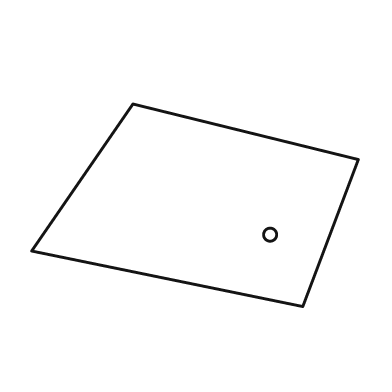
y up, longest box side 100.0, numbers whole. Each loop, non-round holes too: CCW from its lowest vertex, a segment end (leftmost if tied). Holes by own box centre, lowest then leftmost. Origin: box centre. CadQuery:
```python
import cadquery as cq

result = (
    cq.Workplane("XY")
    .moveTo(33.0, -31.0)
    .lineTo(50.0, 14.0)
    .lineTo(-19.0, 31.0)
    .lineTo(-50.0, -14.0)
    .close()
    .moveTo(23.0, -9.0)
    .circle(2.0)
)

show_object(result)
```